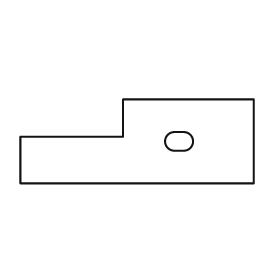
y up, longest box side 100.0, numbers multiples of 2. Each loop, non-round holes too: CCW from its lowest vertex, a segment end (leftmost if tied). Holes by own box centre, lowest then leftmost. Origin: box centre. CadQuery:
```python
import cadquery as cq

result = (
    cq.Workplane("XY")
    .moveTo(-50.0, -18.0)
    .lineTo(50.0, -18.0)
    .lineTo(50.0, 18.0)
    .lineTo(-6.0, 18.0)
    .lineTo(-6.0, 2.0)
    .lineTo(-50.0, 2.0)
    .close()
    .moveTo(16.0, -4.0)
    .lineTo(20.0, -4.0)
    .threePointArc((24.0, 0.0), (20.0, 4.0))
    .lineTo(16.0, 4.0)
    .threePointArc((12.0, 0.0), (16.0, -4.0))
    .close()
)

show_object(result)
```